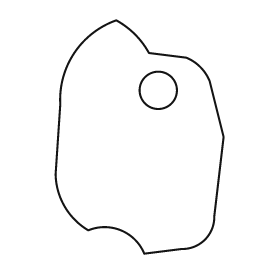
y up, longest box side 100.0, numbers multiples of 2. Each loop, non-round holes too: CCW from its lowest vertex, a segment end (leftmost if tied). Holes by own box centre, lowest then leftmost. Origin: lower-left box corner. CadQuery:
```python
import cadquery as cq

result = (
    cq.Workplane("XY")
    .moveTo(38.0, 0.0)
    .lineTo(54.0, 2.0)
    .threePointArc((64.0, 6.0), (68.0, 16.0))
    .lineTo(72.0, 50.0)
    .lineTo(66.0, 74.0)
    .threePointArc((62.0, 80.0), (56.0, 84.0))
    .lineTo(40.0, 86.0)
    .threePointArc((34.0, 94.0), (26.0, 100.0))
    .threePointArc((8.0, 86.0), (2.0, 64.0))
    .lineTo(0.0, 34.0)
    .threePointArc((4.0, 20.0), (14.0, 10.0))
    .threePointArc((28.0, 10.0), (38.0, 0.0))
    .close()
    .moveTo(44.0, 70.0)
    .circle(8.0)
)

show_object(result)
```